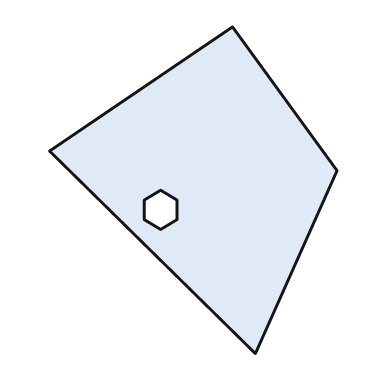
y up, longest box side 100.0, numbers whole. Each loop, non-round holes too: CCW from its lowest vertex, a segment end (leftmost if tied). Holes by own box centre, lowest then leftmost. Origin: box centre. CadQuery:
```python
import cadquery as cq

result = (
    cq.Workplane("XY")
    .moveTo(19.0, -50.0)
    .lineTo(44.0, 6.0)
    .lineTo(12.0, 50.0)
    .lineTo(-44.0, 12.0)
    .close()
    .moveTo(-10.0, -12.0)
    .lineTo(-5.0, -9.0)
    .lineTo(-5.0, -3.0)
    .lineTo(-10.0, 0.0)
    .lineTo(-15.0, -3.0)
    .lineTo(-15.0, -9.0)
    .close()
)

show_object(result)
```